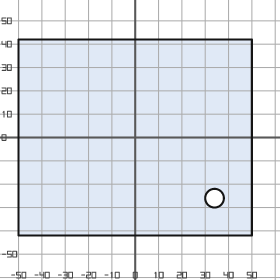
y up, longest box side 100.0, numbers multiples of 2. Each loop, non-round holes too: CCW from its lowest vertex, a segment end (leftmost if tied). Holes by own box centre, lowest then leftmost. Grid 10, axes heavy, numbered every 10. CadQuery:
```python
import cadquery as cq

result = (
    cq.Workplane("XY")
    .moveTo(-50.0, -42.0)
    .lineTo(50.0, -42.0)
    .lineTo(50.0, 42.0)
    .lineTo(-50.0, 42.0)
    .close()
    .moveTo(34.0, -26.0)
    .circle(4.0)
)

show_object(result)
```